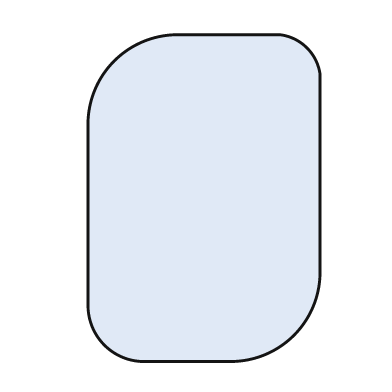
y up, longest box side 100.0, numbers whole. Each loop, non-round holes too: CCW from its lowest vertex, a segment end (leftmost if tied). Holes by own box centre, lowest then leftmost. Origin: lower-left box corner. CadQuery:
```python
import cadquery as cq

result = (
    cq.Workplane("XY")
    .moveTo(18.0, 0.0)
    .lineTo(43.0, 0.0)
    .threePointArc((63.0, 8.0), (71.0, 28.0))
    .lineTo(71.0, 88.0)
    .threePointArc((67.0, 96.0), (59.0, 100.0))
    .lineTo(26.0, 100.0)
    .threePointArc((8.0, 92.0), (0.0, 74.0))
    .lineTo(0.0, 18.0)
    .threePointArc((5.0, 5.0), (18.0, 0.0))
    .close()
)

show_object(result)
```